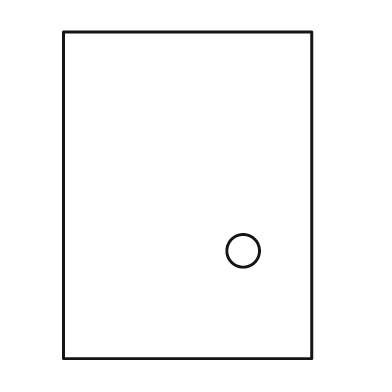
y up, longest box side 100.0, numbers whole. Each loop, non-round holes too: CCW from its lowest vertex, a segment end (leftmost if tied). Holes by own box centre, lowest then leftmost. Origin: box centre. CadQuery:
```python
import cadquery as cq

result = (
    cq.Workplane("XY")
    .moveTo(-38.0, -50.0)
    .lineTo(38.0, -50.0)
    .lineTo(38.0, 50.0)
    .lineTo(-38.0, 50.0)
    .close()
    .moveTo(17.0, -17.0)
    .circle(5.0)
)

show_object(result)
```